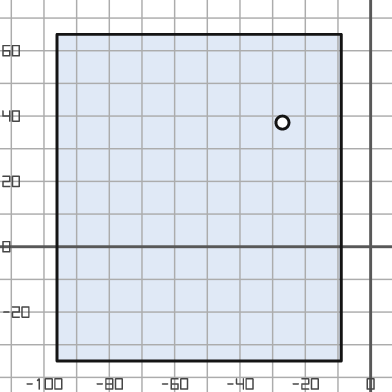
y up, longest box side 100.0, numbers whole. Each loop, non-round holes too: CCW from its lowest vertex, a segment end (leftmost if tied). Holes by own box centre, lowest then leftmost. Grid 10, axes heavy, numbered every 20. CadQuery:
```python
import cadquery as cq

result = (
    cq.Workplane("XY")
    .moveTo(-96.0, -35.0)
    .lineTo(-9.0, -35.0)
    .lineTo(-9.0, 65.0)
    .lineTo(-96.0, 65.0)
    .close()
    .moveTo(-27.0, 38.0)
    .circle(2.0)
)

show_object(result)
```